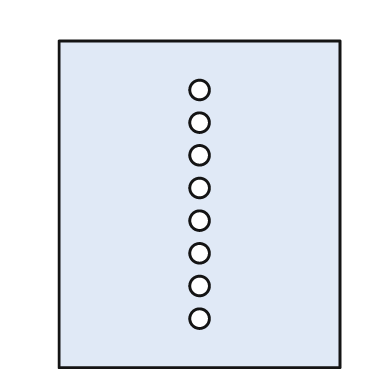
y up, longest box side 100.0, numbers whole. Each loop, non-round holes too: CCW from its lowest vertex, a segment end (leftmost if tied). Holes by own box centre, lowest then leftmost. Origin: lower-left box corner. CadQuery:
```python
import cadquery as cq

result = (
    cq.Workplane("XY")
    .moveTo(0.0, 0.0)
    .lineTo(86.0, 0.0)
    .lineTo(86.0, 100.0)
    .lineTo(0.0, 100.0)
    .close()
    .moveTo(43.0, 15.0)
    .circle(3.0)
    .moveTo(43.0, 25.0)
    .circle(3.0)
    .moveTo(43.0, 35.0)
    .circle(3.0)
    .moveTo(43.0, 45.0)
    .circle(3.0)
    .moveTo(43.0, 55.0)
    .circle(3.0)
    .moveTo(43.0, 65.0)
    .circle(3.0)
    .moveTo(43.0, 75.0)
    .circle(3.0)
    .moveTo(43.0, 85.0)
    .circle(3.0)
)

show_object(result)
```